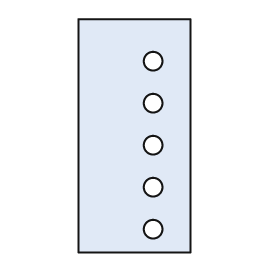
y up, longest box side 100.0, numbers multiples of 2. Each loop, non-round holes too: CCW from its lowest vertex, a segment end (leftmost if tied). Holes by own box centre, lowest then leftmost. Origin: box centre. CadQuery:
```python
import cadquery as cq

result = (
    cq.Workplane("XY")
    .moveTo(-24.0, -50.0)
    .lineTo(24.0, -50.0)
    .lineTo(24.0, 50.0)
    .lineTo(-24.0, 50.0)
    .close()
    .moveTo(8.0, -40.0)
    .circle(4.0)
    .moveTo(8.0, -22.0)
    .circle(4.0)
    .moveTo(8.0, -4.0)
    .circle(4.0)
    .moveTo(8.0, 14.0)
    .circle(4.0)
    .moveTo(8.0, 32.0)
    .circle(4.0)
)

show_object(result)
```